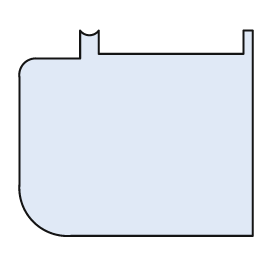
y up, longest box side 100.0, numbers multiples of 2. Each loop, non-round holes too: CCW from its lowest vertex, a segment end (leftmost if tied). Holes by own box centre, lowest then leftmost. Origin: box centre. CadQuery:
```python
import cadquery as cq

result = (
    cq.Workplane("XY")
    .moveTo(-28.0, -44.0)
    .lineTo(50.0, -44.0)
    .lineTo(50.0, 44.0)
    .lineTo(46.0, 44.0)
    .lineTo(46.0, 34.0)
    .lineTo(-16.0, 34.0)
    .lineTo(-16.0, 44.0)
    .threePointArc((-20.0, 42.0), (-24.0, 44.0))
    .lineTo(-24.0, 32.0)
    .lineTo(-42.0, 32.0)
    .threePointArc((-48.0, 30.0), (-50.0, 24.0))
    .lineTo(-50.0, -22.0)
    .threePointArc((-44.0, -38.0), (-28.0, -44.0))
    .close()
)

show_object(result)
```